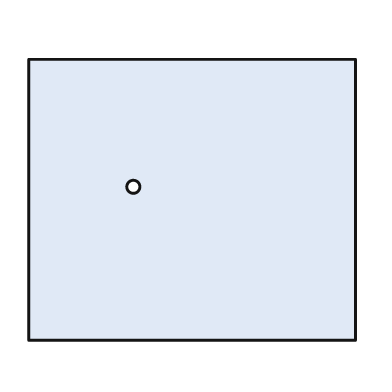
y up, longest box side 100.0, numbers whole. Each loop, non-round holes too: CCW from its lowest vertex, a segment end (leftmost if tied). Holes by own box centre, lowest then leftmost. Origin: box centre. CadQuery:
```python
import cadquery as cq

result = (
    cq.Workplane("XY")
    .moveTo(-50.0, -43.0)
    .lineTo(50.0, -43.0)
    .lineTo(50.0, 43.0)
    .lineTo(-50.0, 43.0)
    .close()
    .moveTo(-18.0, 4.0)
    .circle(2.0)
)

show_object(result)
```